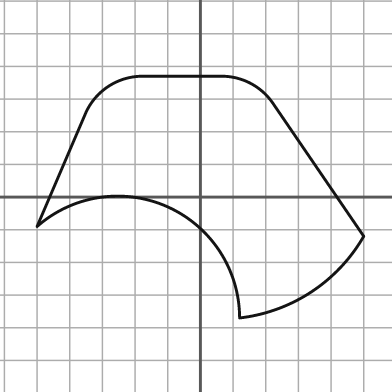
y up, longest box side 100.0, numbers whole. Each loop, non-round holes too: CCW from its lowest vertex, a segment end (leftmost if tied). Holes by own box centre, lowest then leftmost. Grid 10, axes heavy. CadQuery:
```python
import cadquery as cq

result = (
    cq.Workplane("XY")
    .moveTo(12.0, -37.0)
    .threePointArc((34.0, -29.0), (50.0, -12.0))
    .lineTo(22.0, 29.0)
    .threePointArc((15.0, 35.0), (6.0, 37.0))
    .lineTo(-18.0, 37.0)
    .threePointArc((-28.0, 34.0), (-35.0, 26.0))
    .lineTo(-50.0, -9.0)
    .threePointArc((-10.0, -3.0), (12.0, -37.0))
    .close()
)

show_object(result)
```